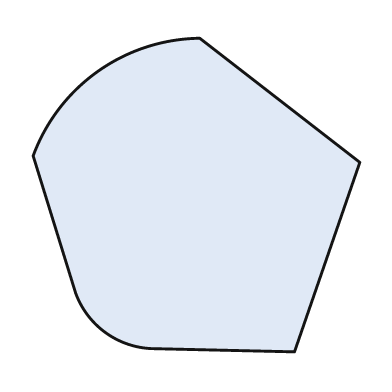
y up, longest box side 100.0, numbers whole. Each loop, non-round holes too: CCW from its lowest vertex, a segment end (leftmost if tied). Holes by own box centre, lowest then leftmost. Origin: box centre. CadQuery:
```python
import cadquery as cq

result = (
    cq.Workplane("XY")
    .moveTo(30.0, -48.0)
    .lineTo(50.0, 10.0)
    .lineTo(1.0, 48.0)
    .threePointArc((-30.0, 38.0), (-50.0, 12.0))
    .lineTo(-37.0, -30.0)
    .threePointArc((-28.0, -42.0), (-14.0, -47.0))
    .close()
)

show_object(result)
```